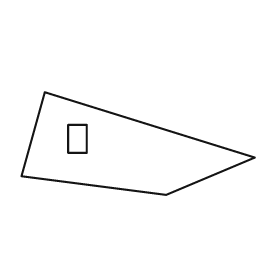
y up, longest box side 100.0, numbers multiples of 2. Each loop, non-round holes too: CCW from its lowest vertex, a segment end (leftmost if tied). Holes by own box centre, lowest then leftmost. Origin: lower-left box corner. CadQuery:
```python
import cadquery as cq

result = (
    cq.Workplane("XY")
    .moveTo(62.0, 0.0)
    .lineTo(100.0, 16.0)
    .lineTo(10.0, 44.0)
    .lineTo(0.0, 8.0)
    .close()
    .moveTo(20.0, 18.0)
    .lineTo(28.0, 18.0)
    .lineTo(28.0, 30.0)
    .lineTo(20.0, 30.0)
    .close()
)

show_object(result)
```